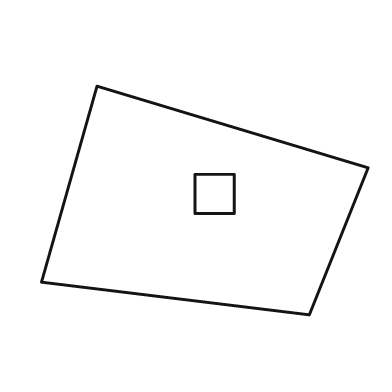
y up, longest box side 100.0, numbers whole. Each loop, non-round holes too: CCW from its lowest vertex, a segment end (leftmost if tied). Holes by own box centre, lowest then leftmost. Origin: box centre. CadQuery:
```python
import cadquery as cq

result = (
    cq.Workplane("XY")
    .moveTo(32.0, -35.0)
    .lineTo(50.0, 10.0)
    .lineTo(-33.0, 35.0)
    .lineTo(-50.0, -25.0)
    .close()
    .moveTo(-3.0, -4.0)
    .lineTo(9.0, -4.0)
    .lineTo(9.0, 8.0)
    .lineTo(-3.0, 8.0)
    .close()
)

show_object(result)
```